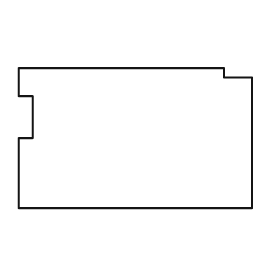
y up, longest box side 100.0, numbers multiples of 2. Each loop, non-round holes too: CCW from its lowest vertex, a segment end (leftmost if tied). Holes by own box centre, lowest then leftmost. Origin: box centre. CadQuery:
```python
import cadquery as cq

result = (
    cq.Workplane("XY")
    .moveTo(-50.0, -30.0)
    .lineTo(50.0, -30.0)
    .lineTo(50.0, 26.0)
    .lineTo(38.0, 26.0)
    .lineTo(38.0, 30.0)
    .lineTo(-50.0, 30.0)
    .lineTo(-50.0, 18.0)
    .lineTo(-44.0, 18.0)
    .lineTo(-44.0, 0.0)
    .lineTo(-50.0, 0.0)
    .close()
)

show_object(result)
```